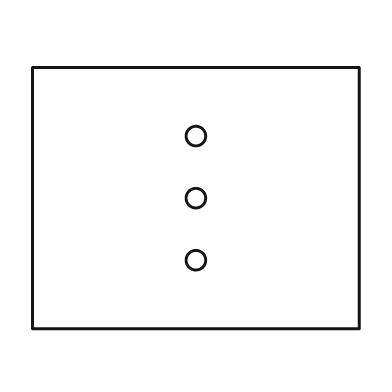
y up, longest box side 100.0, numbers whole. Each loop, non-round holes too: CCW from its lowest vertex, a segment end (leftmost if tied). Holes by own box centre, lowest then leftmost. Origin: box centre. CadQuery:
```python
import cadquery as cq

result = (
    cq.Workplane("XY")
    .moveTo(-50.0, -40.0)
    .lineTo(50.0, -40.0)
    .lineTo(50.0, 40.0)
    .lineTo(-50.0, 40.0)
    .close()
    .moveTo(0.0, -19.0)
    .circle(3.0)
    .moveTo(0.0, 0.0)
    .circle(3.0)
    .moveTo(0.0, 19.0)
    .circle(3.0)
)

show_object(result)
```